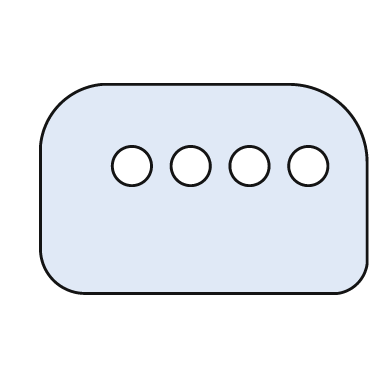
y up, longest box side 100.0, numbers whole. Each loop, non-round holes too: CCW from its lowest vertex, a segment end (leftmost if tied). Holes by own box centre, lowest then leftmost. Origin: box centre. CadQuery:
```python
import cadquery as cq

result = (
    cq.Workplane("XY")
    .moveTo(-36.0, -32.0)
    .lineTo(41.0, -32.0)
    .threePointArc((47.0, -29.0), (50.0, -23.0))
    .lineTo(50.0, 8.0)
    .threePointArc((43.0, 25.0), (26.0, 32.0))
    .lineTo(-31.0, 32.0)
    .threePointArc((-44.0, 26.0), (-50.0, 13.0))
    .lineTo(-50.0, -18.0)
    .threePointArc((-46.0, -28.0), (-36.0, -32.0))
    .close()
    .moveTo(-22.0, 7.0)
    .circle(6.0)
    .moveTo(-4.0, 7.0)
    .circle(6.0)
    .moveTo(14.0, 7.0)
    .circle(6.0)
    .moveTo(32.0, 7.0)
    .circle(6.0)
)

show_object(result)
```